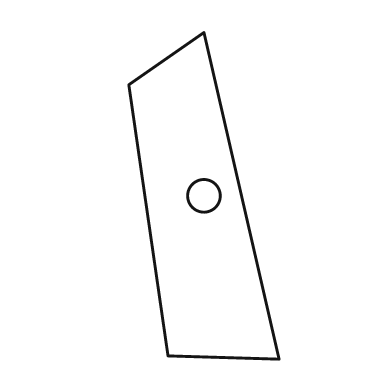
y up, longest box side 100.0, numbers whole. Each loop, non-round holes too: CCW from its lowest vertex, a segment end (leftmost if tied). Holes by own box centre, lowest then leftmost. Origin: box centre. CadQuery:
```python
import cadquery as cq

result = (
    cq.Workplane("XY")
    .moveTo(23.0, -50.0)
    .lineTo(0.0, 50.0)
    .lineTo(-23.0, 34.0)
    .lineTo(-11.0, -49.0)
    .close()
    .moveTo(0.0, 0.0)
    .circle(5.0)
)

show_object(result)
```